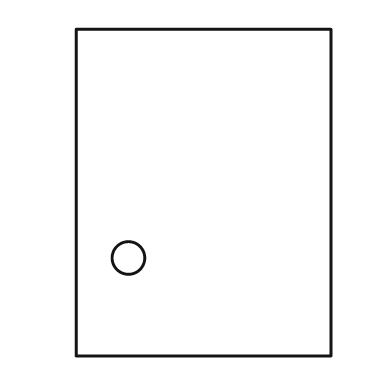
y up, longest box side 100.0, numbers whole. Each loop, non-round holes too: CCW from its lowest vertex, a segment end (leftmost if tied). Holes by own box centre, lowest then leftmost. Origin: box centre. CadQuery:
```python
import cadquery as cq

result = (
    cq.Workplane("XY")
    .moveTo(-39.0, -50.0)
    .lineTo(39.0, -50.0)
    .lineTo(39.0, 50.0)
    .lineTo(-39.0, 50.0)
    .close()
    .moveTo(-23.0, -20.0)
    .circle(5.0)
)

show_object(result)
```